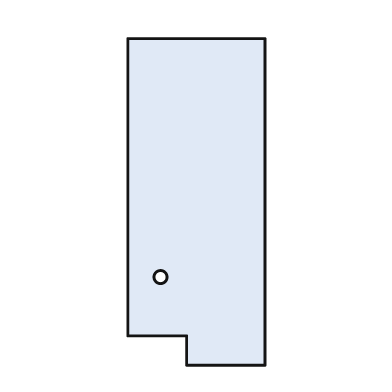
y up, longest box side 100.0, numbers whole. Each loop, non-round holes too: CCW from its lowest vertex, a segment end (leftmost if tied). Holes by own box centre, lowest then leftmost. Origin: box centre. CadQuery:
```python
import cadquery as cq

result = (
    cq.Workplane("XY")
    .moveTo(-3.0, -50.0)
    .lineTo(21.0, -50.0)
    .lineTo(21.0, 50.0)
    .lineTo(-21.0, 50.0)
    .lineTo(-21.0, -41.0)
    .lineTo(-3.0, -41.0)
    .close()
    .moveTo(-11.0, -23.0)
    .circle(2.0)
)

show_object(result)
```